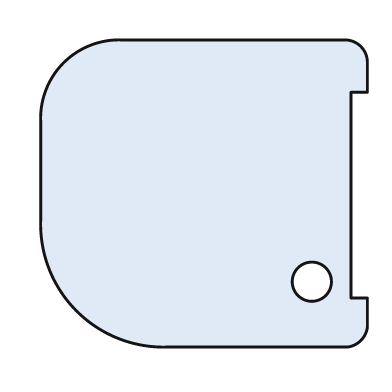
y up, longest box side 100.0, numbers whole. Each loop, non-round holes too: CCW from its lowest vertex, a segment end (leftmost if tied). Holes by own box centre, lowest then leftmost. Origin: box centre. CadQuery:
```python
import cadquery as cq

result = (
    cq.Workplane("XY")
    .moveTo(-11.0, -47.0)
    .lineTo(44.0, -47.0)
    .threePointArc((48.0, -45.0), (50.0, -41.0))
    .lineTo(50.0, -32.0)
    .lineTo(45.0, -32.0)
    .lineTo(45.0, 31.0)
    .lineTo(50.0, 31.0)
    .lineTo(50.0, 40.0)
    .threePointArc((48.0, 45.0), (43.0, 47.0))
    .lineTo(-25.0, 47.0)
    .threePointArc((-43.0, 40.0), (-50.0, 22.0))
    .lineTo(-50.0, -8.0)
    .threePointArc((-39.0, -36.0), (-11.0, -47.0))
    .close()
    .moveTo(33.0, -27.0)
    .circle(6.0)
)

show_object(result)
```